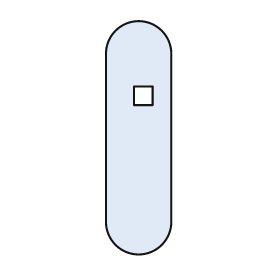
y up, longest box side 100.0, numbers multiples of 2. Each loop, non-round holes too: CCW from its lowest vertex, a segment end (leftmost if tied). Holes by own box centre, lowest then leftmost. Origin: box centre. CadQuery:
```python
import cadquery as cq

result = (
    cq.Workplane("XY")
    .moveTo(-14.0, -36.0)
    .threePointArc((0.0, -50.0), (14.0, -36.0))
    .lineTo(14.0, 36.0)
    .threePointArc((0.0, 50.0), (-14.0, 36.0))
    .close()
    .moveTo(-2.0, 14.0)
    .lineTo(6.0, 14.0)
    .lineTo(6.0, 22.0)
    .lineTo(-2.0, 22.0)
    .close()
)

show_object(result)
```